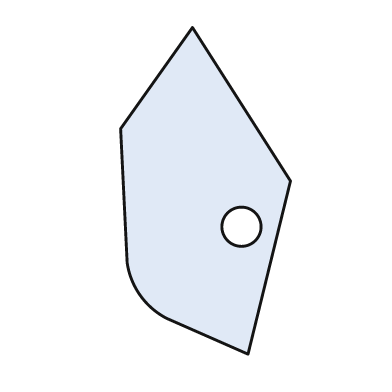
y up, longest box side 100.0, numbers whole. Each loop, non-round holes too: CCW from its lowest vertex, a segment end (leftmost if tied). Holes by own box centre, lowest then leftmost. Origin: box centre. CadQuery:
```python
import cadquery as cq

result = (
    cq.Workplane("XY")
    .moveTo(13.0, -50.0)
    .lineTo(26.0, 3.0)
    .lineTo(-4.0, 50.0)
    .lineTo(-26.0, 19.0)
    .lineTo(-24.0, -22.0)
    .threePointArc((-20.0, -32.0), (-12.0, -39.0))
    .close()
    .moveTo(11.0, -11.0)
    .circle(6.0)
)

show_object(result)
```